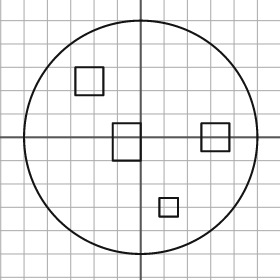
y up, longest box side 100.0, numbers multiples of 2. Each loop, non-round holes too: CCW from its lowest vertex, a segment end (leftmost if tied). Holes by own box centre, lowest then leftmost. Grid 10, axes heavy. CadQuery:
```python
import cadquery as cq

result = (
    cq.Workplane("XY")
    .moveTo(0.0, 0.0)
    .circle(50.0)
    .moveTo(8.0, -34.0)
    .lineTo(16.0, -34.0)
    .lineTo(16.0, -26.0)
    .lineTo(8.0, -26.0)
    .close()
    .moveTo(-12.0, -10.0)
    .lineTo(0.0, -10.0)
    .lineTo(0.0, 6.0)
    .lineTo(-12.0, 6.0)
    .close()
    .moveTo(26.0, -6.0)
    .lineTo(38.0, -6.0)
    .lineTo(38.0, 6.0)
    .lineTo(26.0, 6.0)
    .close()
    .moveTo(-28.0, 18.0)
    .lineTo(-16.0, 18.0)
    .lineTo(-16.0, 30.0)
    .lineTo(-28.0, 30.0)
    .close()
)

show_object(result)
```